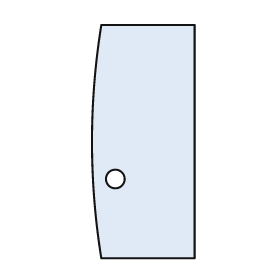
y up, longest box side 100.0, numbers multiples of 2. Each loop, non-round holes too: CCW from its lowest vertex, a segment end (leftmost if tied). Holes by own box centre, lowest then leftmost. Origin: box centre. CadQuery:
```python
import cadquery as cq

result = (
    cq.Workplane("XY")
    .moveTo(-18.0, -50.0)
    .lineTo(22.0, -50.0)
    .lineTo(22.0, 50.0)
    .lineTo(-18.0, 50.0)
    .threePointArc((-22.0, 0.0), (-18.0, -50.0))
    .close()
    .moveTo(-12.0, -16.0)
    .circle(4.0)
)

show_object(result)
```